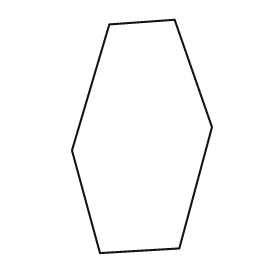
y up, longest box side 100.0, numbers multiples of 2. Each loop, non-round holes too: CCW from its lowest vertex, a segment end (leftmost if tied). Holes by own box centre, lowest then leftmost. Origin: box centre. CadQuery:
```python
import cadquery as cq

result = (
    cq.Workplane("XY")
    .moveTo(-18.0, -50.0)
    .lineTo(16.0, -48.0)
    .lineTo(30.0, 4.0)
    .lineTo(14.0, 50.0)
    .lineTo(-14.0, 48.0)
    .lineTo(-30.0, -6.0)
    .close()
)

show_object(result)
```